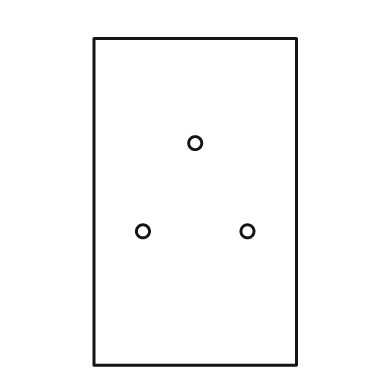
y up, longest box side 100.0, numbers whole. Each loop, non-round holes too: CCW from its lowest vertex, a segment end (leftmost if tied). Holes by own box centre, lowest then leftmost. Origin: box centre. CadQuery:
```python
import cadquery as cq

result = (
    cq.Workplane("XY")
    .moveTo(-31.0, -50.0)
    .lineTo(31.0, -50.0)
    .lineTo(31.0, 50.0)
    .lineTo(-31.0, 50.0)
    .close()
    .moveTo(-16.0, -9.0)
    .circle(2.0)
    .moveTo(16.0, -9.0)
    .circle(2.0)
    .moveTo(0.0, 18.0)
    .circle(2.0)
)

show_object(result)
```